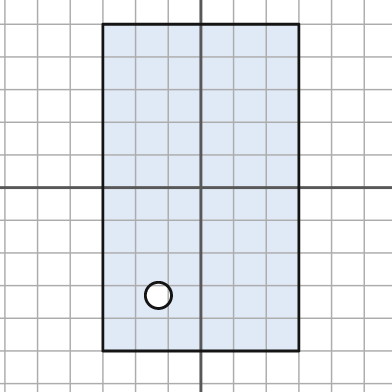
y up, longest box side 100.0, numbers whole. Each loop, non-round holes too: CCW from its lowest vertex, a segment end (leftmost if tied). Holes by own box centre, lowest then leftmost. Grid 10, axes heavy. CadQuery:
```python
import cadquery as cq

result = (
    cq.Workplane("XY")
    .moveTo(-30.0, -50.0)
    .lineTo(30.0, -50.0)
    .lineTo(30.0, 50.0)
    .lineTo(-30.0, 50.0)
    .close()
    .moveTo(-13.0, -33.0)
    .circle(4.0)
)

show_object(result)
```